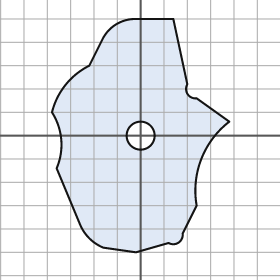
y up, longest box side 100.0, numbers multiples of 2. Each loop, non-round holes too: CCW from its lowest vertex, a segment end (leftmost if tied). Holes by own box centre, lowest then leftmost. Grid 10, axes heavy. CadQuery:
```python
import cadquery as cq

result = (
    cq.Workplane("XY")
    .moveTo(-2.0, -50.0)
    .lineTo(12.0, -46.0)
    .threePointArc((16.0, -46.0), (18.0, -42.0))
    .lineTo(24.0, -30.0)
    .threePointArc((26.0, -10.0), (38.0, 6.0))
    .lineTo(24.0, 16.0)
    .threePointArc((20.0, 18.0), (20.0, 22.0))
    .lineTo(14.0, 50.0)
    .lineTo(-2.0, 50.0)
    .threePointArc((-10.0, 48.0), (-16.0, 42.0))
    .lineTo(-22.0, 30.0)
    .threePointArc((-32.0, 22.0), (-38.0, 10.0))
    .threePointArc((-34.0, -2.0), (-36.0, -14.0))
    .lineTo(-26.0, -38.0)
    .threePointArc((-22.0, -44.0), (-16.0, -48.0))
    .close()
    .moveTo(0.0, 0.0)
    .circle(6.0)
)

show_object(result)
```